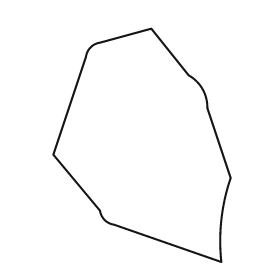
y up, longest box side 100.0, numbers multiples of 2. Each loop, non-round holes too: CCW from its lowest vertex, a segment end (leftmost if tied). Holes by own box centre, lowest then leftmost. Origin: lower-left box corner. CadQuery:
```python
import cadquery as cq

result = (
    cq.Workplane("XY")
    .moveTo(72.0, 0.0)
    .threePointArc((72.0, 18.0), (76.0, 36.0))
    .lineTo(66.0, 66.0)
    .threePointArc((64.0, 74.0), (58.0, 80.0))
    .lineTo(42.0, 100.0)
    .lineTo(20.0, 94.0)
    .threePointArc((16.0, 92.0), (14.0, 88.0))
    .lineTo(0.0, 46.0)
    .lineTo(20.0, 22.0)
    .threePointArc((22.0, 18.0), (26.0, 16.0))
    .close()
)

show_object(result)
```